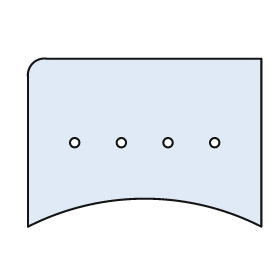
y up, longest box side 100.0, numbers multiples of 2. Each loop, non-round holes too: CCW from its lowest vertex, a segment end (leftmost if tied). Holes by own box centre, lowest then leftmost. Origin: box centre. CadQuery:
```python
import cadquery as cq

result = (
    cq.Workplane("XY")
    .moveTo(-50.0, -36.0)
    .threePointArc((0.0, -24.0), (50.0, -36.0))
    .lineTo(50.0, 36.0)
    .lineTo(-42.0, 36.0)
    .threePointArc((-48.0, 34.0), (-50.0, 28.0))
    .close()
    .moveTo(-30.0, 0.0)
    .circle(2.0)
    .moveTo(-10.0, 0.0)
    .circle(2.0)
    .moveTo(10.0, 0.0)
    .circle(2.0)
    .moveTo(30.0, 0.0)
    .circle(2.0)
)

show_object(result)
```